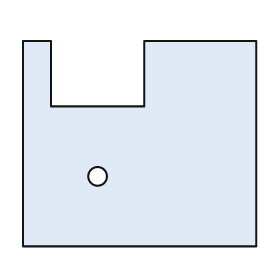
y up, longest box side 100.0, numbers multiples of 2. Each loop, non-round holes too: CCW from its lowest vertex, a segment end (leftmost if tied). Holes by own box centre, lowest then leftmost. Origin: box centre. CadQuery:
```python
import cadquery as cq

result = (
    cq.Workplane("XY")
    .moveTo(-50.0, -44.0)
    .lineTo(50.0, -44.0)
    .lineTo(50.0, 44.0)
    .lineTo(2.0, 44.0)
    .lineTo(2.0, 16.0)
    .lineTo(-38.0, 16.0)
    .lineTo(-38.0, 44.0)
    .lineTo(-50.0, 44.0)
    .close()
    .moveTo(-18.0, -14.0)
    .circle(4.0)
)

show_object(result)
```